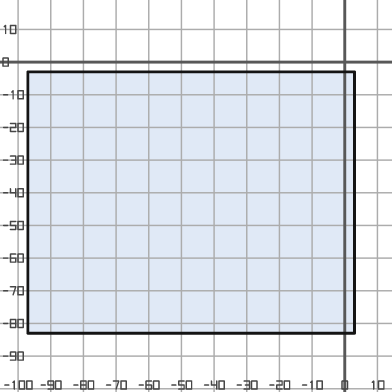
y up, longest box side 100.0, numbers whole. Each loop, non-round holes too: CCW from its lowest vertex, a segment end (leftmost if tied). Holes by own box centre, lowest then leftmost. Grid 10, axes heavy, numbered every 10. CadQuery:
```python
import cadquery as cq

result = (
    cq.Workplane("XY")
    .moveTo(-97.0, -83.0)
    .lineTo(3.0, -83.0)
    .lineTo(3.0, -3.0)
    .lineTo(-97.0, -3.0)
    .close()
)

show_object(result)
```